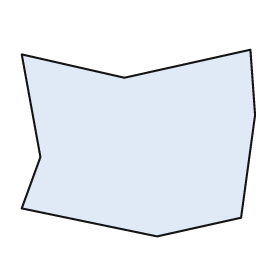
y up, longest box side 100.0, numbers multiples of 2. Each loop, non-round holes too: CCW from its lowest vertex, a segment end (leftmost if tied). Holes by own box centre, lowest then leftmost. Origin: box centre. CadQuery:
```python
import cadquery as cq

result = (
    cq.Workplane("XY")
    .moveTo(8.0, -40.0)
    .lineTo(44.0, -32.0)
    .lineTo(50.0, 12.0)
    .lineTo(48.0, 40.0)
    .lineTo(-6.0, 28.0)
    .lineTo(-50.0, 38.0)
    .lineTo(-42.0, -6.0)
    .lineTo(-50.0, -28.0)
    .close()
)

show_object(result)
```